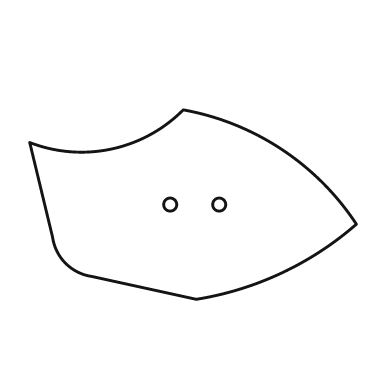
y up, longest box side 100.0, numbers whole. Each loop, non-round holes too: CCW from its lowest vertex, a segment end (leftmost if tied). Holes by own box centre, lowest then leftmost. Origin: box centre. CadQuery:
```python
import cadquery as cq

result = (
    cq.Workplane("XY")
    .moveTo(1.0, -29.0)
    .threePointArc((27.0, -21.0), (50.0, -6.0))
    .threePointArc((27.0, 17.0), (-3.0, 29.0))
    .threePointArc((-25.0, 17.0), (-50.0, 19.0))
    .lineTo(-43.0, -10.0)
    .threePointArc((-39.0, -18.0), (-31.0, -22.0))
    .close()
    .moveTo(-7.0, 0.0)
    .circle(2.0)
    .moveTo(8.0, 0.0)
    .circle(2.0)
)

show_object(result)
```